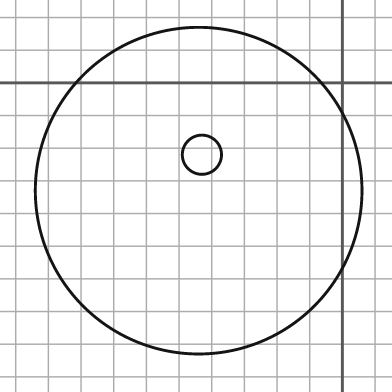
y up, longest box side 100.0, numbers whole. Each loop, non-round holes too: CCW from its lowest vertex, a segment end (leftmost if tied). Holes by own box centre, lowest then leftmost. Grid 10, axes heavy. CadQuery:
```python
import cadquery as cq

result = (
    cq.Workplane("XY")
    .moveTo(-44.0, -33.0)
    .circle(50.0)
    .moveTo(-43.0, -22.0)
    .circle(6.0)
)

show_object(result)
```